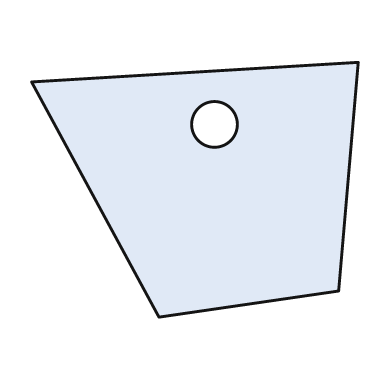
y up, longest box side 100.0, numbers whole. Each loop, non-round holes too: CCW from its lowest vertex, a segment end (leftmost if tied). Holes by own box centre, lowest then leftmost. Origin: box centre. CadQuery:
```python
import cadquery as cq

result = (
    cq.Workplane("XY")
    .moveTo(-11.0, -39.0)
    .lineTo(44.0, -31.0)
    .lineTo(50.0, 39.0)
    .lineTo(-50.0, 33.0)
    .close()
    .moveTo(6.0, 20.0)
    .circle(7.0)
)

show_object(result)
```